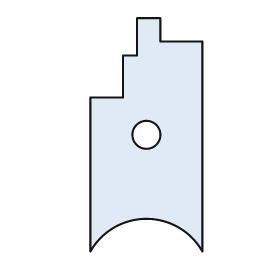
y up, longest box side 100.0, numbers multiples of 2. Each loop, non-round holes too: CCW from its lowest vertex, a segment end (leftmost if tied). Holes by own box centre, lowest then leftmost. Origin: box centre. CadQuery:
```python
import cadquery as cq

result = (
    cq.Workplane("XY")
    .moveTo(-24.0, -50.0)
    .threePointArc((0.0, -36.0), (24.0, -50.0))
    .lineTo(24.0, 40.0)
    .lineTo(6.0, 40.0)
    .lineTo(6.0, 50.0)
    .lineTo(-4.0, 50.0)
    .lineTo(-4.0, 34.0)
    .lineTo(-10.0, 34.0)
    .lineTo(-10.0, 16.0)
    .lineTo(-24.0, 16.0)
    .close()
    .moveTo(0.0, 0.0)
    .circle(6.0)
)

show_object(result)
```